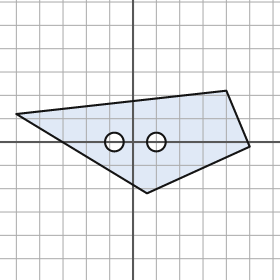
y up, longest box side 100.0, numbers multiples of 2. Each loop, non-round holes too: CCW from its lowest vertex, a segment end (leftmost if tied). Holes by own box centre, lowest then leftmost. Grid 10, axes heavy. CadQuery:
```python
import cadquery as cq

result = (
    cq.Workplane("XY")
    .moveTo(6.0, -22.0)
    .lineTo(50.0, -2.0)
    .lineTo(40.0, 22.0)
    .lineTo(-50.0, 12.0)
    .close()
    .moveTo(-8.0, 0.0)
    .circle(4.0)
    .moveTo(10.0, 0.0)
    .circle(4.0)
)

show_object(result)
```